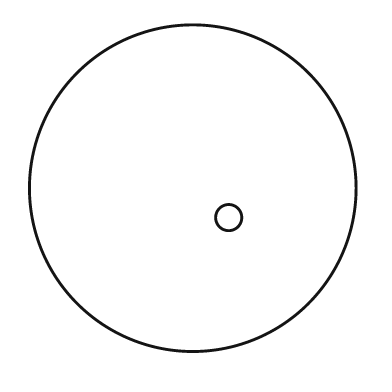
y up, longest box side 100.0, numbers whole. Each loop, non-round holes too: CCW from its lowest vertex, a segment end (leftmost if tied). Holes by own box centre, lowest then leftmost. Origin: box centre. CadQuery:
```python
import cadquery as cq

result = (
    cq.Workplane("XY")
    .moveTo(0.0, 0.0)
    .circle(50.0)
    .moveTo(11.0, -9.0)
    .circle(4.0)
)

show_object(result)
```